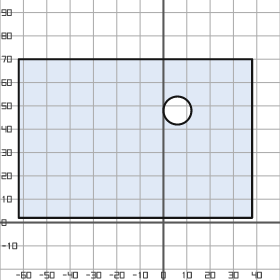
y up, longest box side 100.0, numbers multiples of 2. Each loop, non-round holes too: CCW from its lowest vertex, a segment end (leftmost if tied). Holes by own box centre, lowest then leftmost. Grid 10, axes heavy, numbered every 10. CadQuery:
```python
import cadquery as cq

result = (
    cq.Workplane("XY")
    .moveTo(-62.0, 2.0)
    .lineTo(38.0, 2.0)
    .lineTo(38.0, 70.0)
    .lineTo(-62.0, 70.0)
    .close()
    .moveTo(6.0, 48.0)
    .circle(6.0)
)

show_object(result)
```